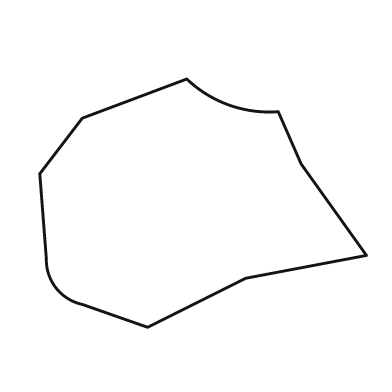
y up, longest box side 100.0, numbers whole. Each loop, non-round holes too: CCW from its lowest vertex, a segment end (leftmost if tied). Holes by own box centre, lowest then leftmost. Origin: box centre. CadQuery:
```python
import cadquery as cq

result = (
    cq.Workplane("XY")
    .moveTo(-17.0, -38.0)
    .lineTo(13.0, -23.0)
    .lineTo(50.0, -16.0)
    .lineTo(30.0, 12.0)
    .lineTo(23.0, 28.0)
    .threePointArc((8.0, 30.0), (-5.0, 38.0))
    .lineTo(-37.0, 26.0)
    .lineTo(-50.0, 9.0)
    .lineTo(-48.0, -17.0)
    .threePointArc((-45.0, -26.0), (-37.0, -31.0))
    .close()
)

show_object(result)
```